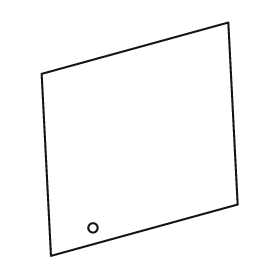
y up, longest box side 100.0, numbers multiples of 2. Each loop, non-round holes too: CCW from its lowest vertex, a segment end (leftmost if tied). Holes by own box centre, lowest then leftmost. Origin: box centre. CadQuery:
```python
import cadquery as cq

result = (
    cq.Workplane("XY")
    .moveTo(-38.0, -50.0)
    .lineTo(42.0, -28.0)
    .lineTo(38.0, 50.0)
    .lineTo(-42.0, 28.0)
    .close()
    .moveTo(-20.0, -38.0)
    .circle(2.0)
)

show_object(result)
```